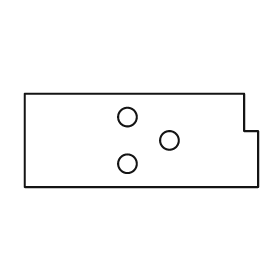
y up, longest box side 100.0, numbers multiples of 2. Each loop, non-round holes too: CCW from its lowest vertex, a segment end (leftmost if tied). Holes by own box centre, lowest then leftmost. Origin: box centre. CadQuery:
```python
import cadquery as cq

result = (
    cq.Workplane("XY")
    .moveTo(-50.0, -20.0)
    .lineTo(50.0, -20.0)
    .lineTo(50.0, 4.0)
    .lineTo(44.0, 4.0)
    .lineTo(44.0, 20.0)
    .lineTo(-50.0, 20.0)
    .close()
    .moveTo(-6.0, -10.0)
    .circle(4.0)
    .moveTo(12.0, 0.0)
    .circle(4.0)
    .moveTo(-6.0, 10.0)
    .circle(4.0)
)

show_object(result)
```